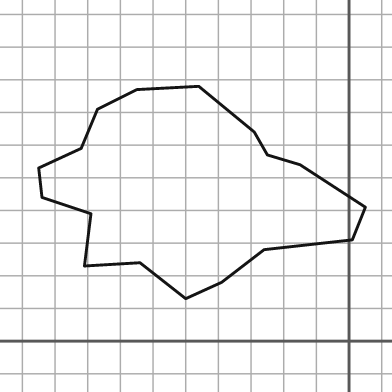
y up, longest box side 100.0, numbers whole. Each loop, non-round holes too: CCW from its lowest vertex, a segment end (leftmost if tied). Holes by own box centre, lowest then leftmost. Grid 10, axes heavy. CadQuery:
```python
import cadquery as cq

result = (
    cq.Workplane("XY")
    .moveTo(-50.0, 13.0)
    .lineTo(-39.0, 18.0)
    .lineTo(-26.0, 28.0)
    .lineTo(1.0, 31.0)
    .lineTo(5.0, 41.0)
    .lineTo(-15.0, 54.0)
    .lineTo(-25.0, 57.0)
    .lineTo(-29.0, 64.0)
    .lineTo(-46.0, 78.0)
    .lineTo(-65.0, 77.0)
    .lineTo(-77.0, 71.0)
    .lineTo(-82.0, 59.0)
    .lineTo(-95.0, 53.0)
    .lineTo(-94.0, 44.0)
    .lineTo(-79.0, 39.0)
    .lineTo(-81.0, 23.0)
    .lineTo(-64.0, 24.0)
    .close()
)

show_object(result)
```